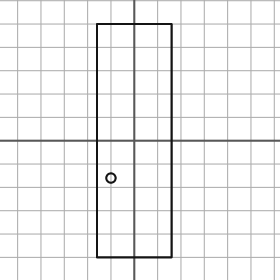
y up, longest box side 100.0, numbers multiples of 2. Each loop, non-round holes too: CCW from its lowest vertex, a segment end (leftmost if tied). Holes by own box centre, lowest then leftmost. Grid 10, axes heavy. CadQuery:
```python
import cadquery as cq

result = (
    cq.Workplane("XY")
    .moveTo(-16.0, -50.0)
    .lineTo(16.0, -50.0)
    .lineTo(16.0, 50.0)
    .lineTo(-16.0, 50.0)
    .close()
    .moveTo(-10.0, -16.0)
    .circle(2.0)
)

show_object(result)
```